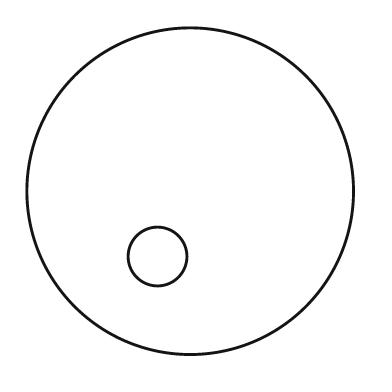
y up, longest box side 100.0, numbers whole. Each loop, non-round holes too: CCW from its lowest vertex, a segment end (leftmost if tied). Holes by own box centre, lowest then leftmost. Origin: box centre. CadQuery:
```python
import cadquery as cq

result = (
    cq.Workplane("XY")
    .moveTo(0.0, 0.0)
    .circle(50.0)
    .moveTo(-10.0, -20.0)
    .circle(9.0)
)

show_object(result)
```